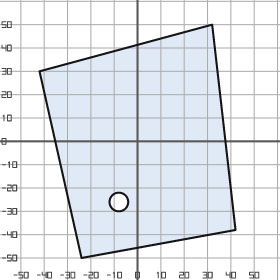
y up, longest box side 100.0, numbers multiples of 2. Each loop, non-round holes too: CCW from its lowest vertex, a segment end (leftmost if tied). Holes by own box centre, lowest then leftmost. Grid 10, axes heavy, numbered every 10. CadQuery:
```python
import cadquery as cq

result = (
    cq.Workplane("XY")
    .moveTo(-24.0, -50.0)
    .lineTo(42.0, -38.0)
    .lineTo(32.0, 50.0)
    .lineTo(-42.0, 30.0)
    .close()
    .moveTo(-8.0, -26.0)
    .circle(4.0)
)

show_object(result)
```